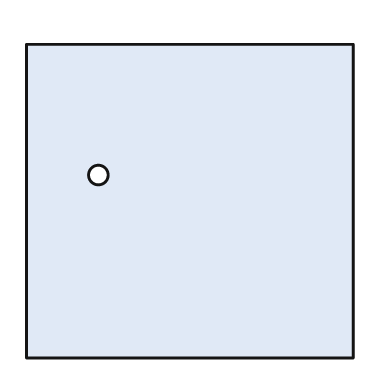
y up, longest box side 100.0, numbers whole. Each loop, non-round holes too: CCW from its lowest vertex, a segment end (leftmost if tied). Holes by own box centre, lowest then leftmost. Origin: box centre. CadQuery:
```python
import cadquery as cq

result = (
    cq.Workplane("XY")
    .moveTo(-50.0, -48.0)
    .lineTo(50.0, -48.0)
    .lineTo(50.0, 48.0)
    .lineTo(-50.0, 48.0)
    .close()
    .moveTo(-28.0, 8.0)
    .circle(3.0)
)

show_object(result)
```